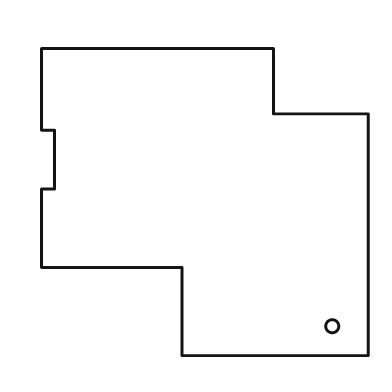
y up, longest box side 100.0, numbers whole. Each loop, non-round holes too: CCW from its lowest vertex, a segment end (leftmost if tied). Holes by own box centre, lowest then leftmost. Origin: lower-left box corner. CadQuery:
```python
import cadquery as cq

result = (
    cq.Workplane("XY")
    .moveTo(43.0, 0.0)
    .lineTo(100.0, 0.0)
    .lineTo(100.0, 74.0)
    .lineTo(71.0, 74.0)
    .lineTo(71.0, 94.0)
    .lineTo(0.0, 94.0)
    .lineTo(0.0, 69.0)
    .lineTo(4.0, 69.0)
    .lineTo(4.0, 51.0)
    .lineTo(0.0, 51.0)
    .lineTo(0.0, 27.0)
    .lineTo(43.0, 27.0)
    .close()
    .moveTo(89.0, 9.0)
    .circle(2.0)
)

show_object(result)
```